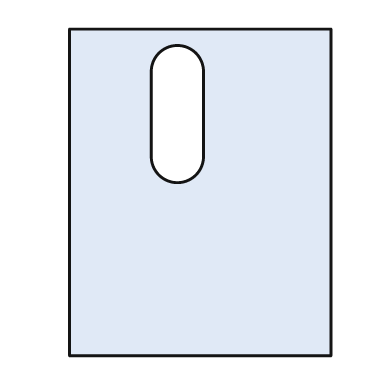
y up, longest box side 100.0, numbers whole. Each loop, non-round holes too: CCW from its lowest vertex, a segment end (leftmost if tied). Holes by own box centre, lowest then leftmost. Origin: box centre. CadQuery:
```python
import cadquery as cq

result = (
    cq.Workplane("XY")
    .moveTo(-40.0, -50.0)
    .lineTo(40.0, -50.0)
    .lineTo(40.0, 50.0)
    .lineTo(-40.0, 50.0)
    .close()
    .moveTo(-15.0, 11.0)
    .threePointArc((-7.0, 3.0), (1.0, 11.0))
    .lineTo(1.0, 37.0)
    .threePointArc((-7.0, 45.0), (-15.0, 37.0))
    .close()
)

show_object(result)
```